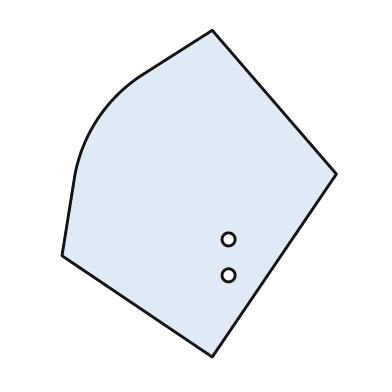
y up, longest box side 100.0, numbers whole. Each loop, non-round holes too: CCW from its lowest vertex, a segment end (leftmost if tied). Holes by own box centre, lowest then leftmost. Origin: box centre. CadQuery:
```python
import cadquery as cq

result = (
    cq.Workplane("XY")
    .moveTo(4.0, -50.0)
    .lineTo(42.0, 6.0)
    .lineTo(4.0, 50.0)
    .lineTo(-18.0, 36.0)
    .threePointArc((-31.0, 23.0), (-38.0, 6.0))
    .lineTo(-42.0, -19.0)
    .close()
    .moveTo(9.0, -25.0)
    .circle(2.0)
    .moveTo(9.0, -14.0)
    .circle(2.0)
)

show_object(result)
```